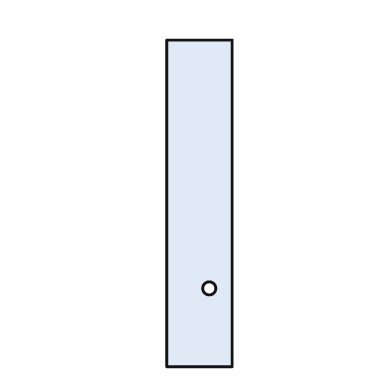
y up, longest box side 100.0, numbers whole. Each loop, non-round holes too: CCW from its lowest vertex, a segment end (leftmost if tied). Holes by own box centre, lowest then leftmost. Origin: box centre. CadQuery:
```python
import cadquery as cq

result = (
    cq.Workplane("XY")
    .moveTo(-10.0, -50.0)
    .lineTo(10.0, -50.0)
    .lineTo(10.0, 50.0)
    .lineTo(-10.0, 50.0)
    .close()
    .moveTo(3.0, -26.0)
    .circle(2.0)
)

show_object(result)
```